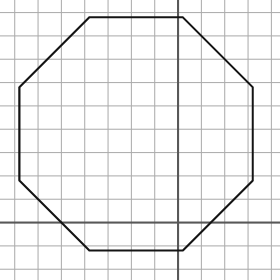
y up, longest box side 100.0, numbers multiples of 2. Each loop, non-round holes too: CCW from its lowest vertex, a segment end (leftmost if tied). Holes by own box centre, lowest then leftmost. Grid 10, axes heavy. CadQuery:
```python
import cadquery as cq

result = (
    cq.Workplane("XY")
    .moveTo(-38.0, -12.0)
    .lineTo(2.0, -12.0)
    .lineTo(32.0, 18.0)
    .lineTo(32.0, 58.0)
    .lineTo(2.0, 88.0)
    .lineTo(-38.0, 88.0)
    .lineTo(-68.0, 58.0)
    .lineTo(-68.0, 18.0)
    .close()
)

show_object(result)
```